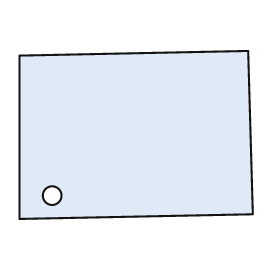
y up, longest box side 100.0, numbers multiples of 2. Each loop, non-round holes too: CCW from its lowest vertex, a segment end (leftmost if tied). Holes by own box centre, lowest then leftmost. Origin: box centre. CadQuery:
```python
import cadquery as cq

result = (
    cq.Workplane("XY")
    .moveTo(-50.0, -36.0)
    .lineTo(50.0, -34.0)
    .lineTo(48.0, 36.0)
    .lineTo(-50.0, 34.0)
    .close()
    .moveTo(-36.0, -26.0)
    .circle(4.0)
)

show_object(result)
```